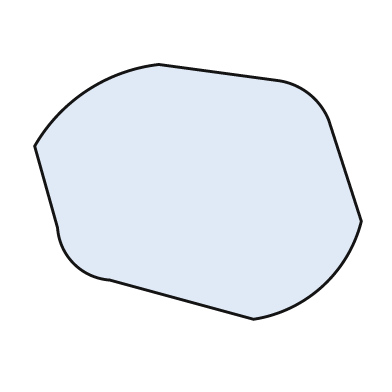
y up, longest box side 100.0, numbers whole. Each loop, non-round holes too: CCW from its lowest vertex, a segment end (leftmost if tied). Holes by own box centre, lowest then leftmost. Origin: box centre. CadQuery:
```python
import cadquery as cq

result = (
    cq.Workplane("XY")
    .moveTo(17.0, -39.0)
    .threePointArc((38.0, -29.0), (50.0, -9.0))
    .lineTo(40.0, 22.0)
    .threePointArc((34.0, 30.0), (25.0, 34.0))
    .lineTo(-12.0, 39.0)
    .threePointArc((-34.0, 31.0), (-50.0, 14.0))
    .lineTo(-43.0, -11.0)
    .threePointArc((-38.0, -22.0), (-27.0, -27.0))
    .close()
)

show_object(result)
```